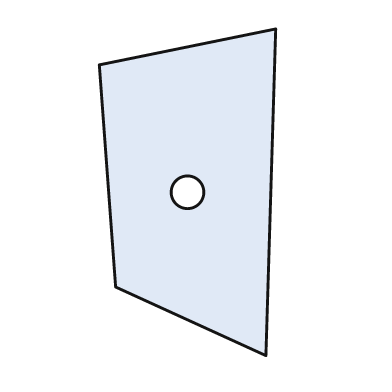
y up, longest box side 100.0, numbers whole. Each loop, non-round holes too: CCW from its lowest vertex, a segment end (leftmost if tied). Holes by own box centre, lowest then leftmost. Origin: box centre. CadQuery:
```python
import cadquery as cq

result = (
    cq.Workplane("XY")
    .moveTo(24.0, -50.0)
    .lineTo(27.0, 50.0)
    .lineTo(-27.0, 39.0)
    .lineTo(-22.0, -29.0)
    .close()
    .moveTo(0.0, 0.0)
    .circle(5.0)
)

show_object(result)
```